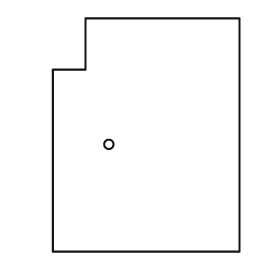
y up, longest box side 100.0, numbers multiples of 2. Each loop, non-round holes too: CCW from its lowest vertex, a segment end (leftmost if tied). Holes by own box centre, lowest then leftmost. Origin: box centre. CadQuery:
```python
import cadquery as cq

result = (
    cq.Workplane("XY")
    .moveTo(-40.0, -50.0)
    .lineTo(40.0, -50.0)
    .lineTo(40.0, 50.0)
    .lineTo(-26.0, 50.0)
    .lineTo(-26.0, 28.0)
    .lineTo(-40.0, 28.0)
    .close()
    .moveTo(-16.0, -4.0)
    .circle(2.0)
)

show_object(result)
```